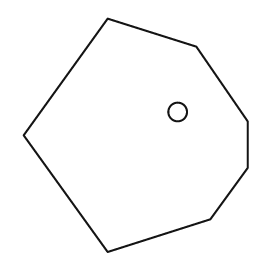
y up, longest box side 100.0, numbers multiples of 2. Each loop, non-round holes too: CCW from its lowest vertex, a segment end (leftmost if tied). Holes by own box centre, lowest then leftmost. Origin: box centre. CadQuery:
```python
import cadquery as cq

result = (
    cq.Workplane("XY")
    .moveTo(-12.0, -50.0)
    .lineTo(32.0, -36.0)
    .lineTo(48.0, -14.0)
    .lineTo(48.0, 6.0)
    .lineTo(26.0, 38.0)
    .lineTo(-12.0, 50.0)
    .lineTo(-48.0, 0.0)
    .close()
    .moveTo(18.0, 10.0)
    .circle(4.0)
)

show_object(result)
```